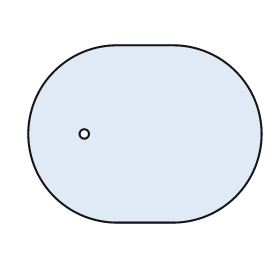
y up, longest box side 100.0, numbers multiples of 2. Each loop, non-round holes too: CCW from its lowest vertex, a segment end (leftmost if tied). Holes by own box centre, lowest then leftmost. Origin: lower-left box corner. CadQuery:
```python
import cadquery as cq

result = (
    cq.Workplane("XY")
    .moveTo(38.0, 0.0)
    .lineTo(62.0, 0.0)
    .threePointArc((100.0, 38.0), (62.0, 76.0))
    .lineTo(38.0, 76.0)
    .threePointArc((0.0, 38.0), (38.0, 0.0))
    .close()
    .moveTo(24.0, 38.0)
    .circle(2.0)
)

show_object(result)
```